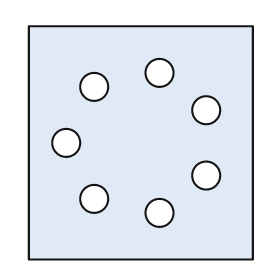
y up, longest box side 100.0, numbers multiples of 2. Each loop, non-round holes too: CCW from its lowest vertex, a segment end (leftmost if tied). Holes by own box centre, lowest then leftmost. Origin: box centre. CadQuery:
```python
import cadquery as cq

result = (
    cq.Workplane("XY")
    .moveTo(-48.0, -50.0)
    .lineTo(48.0, -50.0)
    .lineTo(48.0, 50.0)
    .lineTo(-48.0, 50.0)
    .close()
    .moveTo(8.0, -30.0)
    .circle(6.0)
    .moveTo(-20.0, -24.0)
    .circle(6.0)
    .moveTo(28.0, -14.0)
    .circle(6.0)
    .moveTo(-32.0, 0.0)
    .circle(6.0)
    .moveTo(28.0, 14.0)
    .circle(6.0)
    .moveTo(-20.0, 24.0)
    .circle(6.0)
    .moveTo(8.0, 30.0)
    .circle(6.0)
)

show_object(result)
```